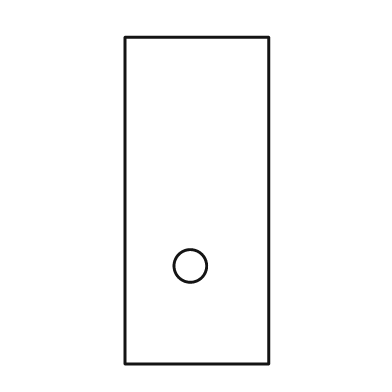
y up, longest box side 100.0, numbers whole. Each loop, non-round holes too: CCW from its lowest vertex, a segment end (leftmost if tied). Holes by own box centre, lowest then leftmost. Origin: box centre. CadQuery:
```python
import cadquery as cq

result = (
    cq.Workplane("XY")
    .moveTo(-22.0, -50.0)
    .lineTo(22.0, -50.0)
    .lineTo(22.0, 50.0)
    .lineTo(-22.0, 50.0)
    .close()
    .moveTo(-2.0, -20.0)
    .circle(5.0)
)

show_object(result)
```